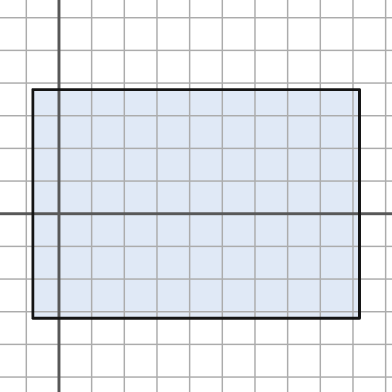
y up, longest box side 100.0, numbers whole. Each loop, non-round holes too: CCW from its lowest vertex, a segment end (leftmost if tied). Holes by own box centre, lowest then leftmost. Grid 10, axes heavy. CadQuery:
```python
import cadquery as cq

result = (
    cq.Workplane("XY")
    .moveTo(-8.0, -32.0)
    .lineTo(92.0, -32.0)
    .lineTo(92.0, 38.0)
    .lineTo(-8.0, 38.0)
    .close()
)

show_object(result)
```